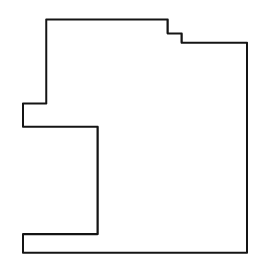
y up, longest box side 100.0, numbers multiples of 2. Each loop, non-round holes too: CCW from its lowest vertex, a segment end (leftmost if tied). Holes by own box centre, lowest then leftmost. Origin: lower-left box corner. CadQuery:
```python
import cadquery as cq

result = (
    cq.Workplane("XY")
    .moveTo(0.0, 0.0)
    .lineTo(96.0, 0.0)
    .lineTo(96.0, 90.0)
    .lineTo(68.0, 90.0)
    .lineTo(68.0, 94.0)
    .lineTo(62.0, 94.0)
    .lineTo(62.0, 100.0)
    .lineTo(10.0, 100.0)
    .lineTo(10.0, 64.0)
    .lineTo(0.0, 64.0)
    .lineTo(0.0, 54.0)
    .lineTo(32.0, 54.0)
    .lineTo(32.0, 8.0)
    .lineTo(0.0, 8.0)
    .close()
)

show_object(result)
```